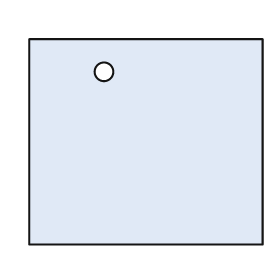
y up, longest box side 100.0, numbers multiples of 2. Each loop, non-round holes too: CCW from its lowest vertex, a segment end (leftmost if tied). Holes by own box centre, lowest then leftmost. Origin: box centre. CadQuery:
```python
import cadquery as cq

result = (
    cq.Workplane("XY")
    .moveTo(-50.0, -44.0)
    .lineTo(50.0, -44.0)
    .lineTo(50.0, 44.0)
    .lineTo(-50.0, 44.0)
    .close()
    .moveTo(-18.0, 30.0)
    .circle(4.0)
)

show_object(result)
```